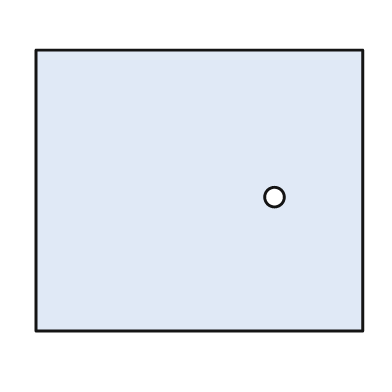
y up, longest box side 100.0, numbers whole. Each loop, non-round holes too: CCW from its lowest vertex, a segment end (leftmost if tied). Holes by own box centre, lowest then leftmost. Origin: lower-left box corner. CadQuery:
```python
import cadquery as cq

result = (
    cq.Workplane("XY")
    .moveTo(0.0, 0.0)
    .lineTo(100.0, 0.0)
    .lineTo(100.0, 86.0)
    .lineTo(0.0, 86.0)
    .close()
    .moveTo(73.0, 41.0)
    .circle(3.0)
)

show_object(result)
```